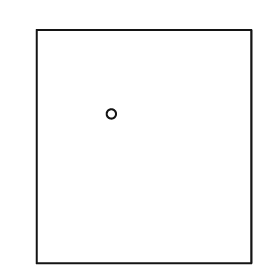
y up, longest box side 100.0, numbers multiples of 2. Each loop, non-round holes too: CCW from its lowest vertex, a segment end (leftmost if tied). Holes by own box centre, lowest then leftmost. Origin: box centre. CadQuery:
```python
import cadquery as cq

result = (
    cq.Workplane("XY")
    .moveTo(-46.0, -50.0)
    .lineTo(46.0, -50.0)
    .lineTo(46.0, 50.0)
    .lineTo(-46.0, 50.0)
    .close()
    .moveTo(-14.0, 14.0)
    .circle(2.0)
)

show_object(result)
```